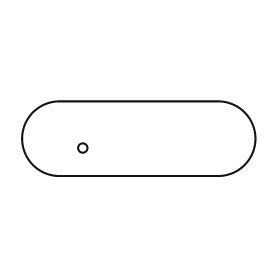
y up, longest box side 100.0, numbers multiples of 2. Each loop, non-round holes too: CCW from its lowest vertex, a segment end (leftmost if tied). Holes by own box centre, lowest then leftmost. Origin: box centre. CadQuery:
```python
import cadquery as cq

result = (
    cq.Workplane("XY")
    .moveTo(-34.0, -16.0)
    .lineTo(34.0, -16.0)
    .threePointArc((50.0, 0.0), (34.0, 16.0))
    .lineTo(-34.0, 16.0)
    .threePointArc((-50.0, 0.0), (-34.0, -16.0))
    .close()
    .moveTo(-24.0, -4.0)
    .circle(2.0)
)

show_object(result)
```